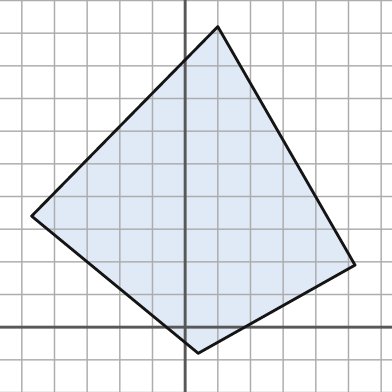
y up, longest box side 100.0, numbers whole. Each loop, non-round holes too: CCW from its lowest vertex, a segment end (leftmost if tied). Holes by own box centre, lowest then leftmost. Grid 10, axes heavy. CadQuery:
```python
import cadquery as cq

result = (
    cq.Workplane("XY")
    .moveTo(4.0, -8.0)
    .lineTo(52.0, 19.0)
    .lineTo(10.0, 92.0)
    .lineTo(-47.0, 34.0)
    .close()
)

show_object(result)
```